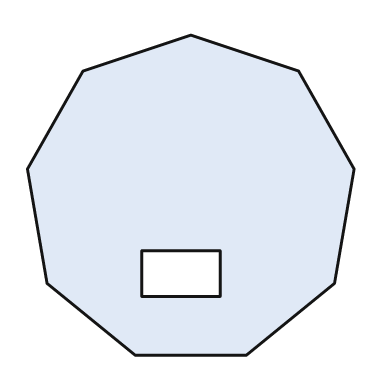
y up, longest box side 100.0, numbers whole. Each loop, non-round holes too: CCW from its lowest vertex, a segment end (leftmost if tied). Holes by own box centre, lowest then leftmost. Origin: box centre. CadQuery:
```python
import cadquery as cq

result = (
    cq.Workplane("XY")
    .moveTo(-17.0, -49.0)
    .lineTo(17.0, -49.0)
    .lineTo(44.0, -27.0)
    .lineTo(50.0, 8.0)
    .lineTo(33.0, 38.0)
    .lineTo(0.0, 49.0)
    .lineTo(-33.0, 38.0)
    .lineTo(-50.0, 8.0)
    .lineTo(-44.0, -27.0)
    .close()
    .moveTo(-15.0, -31.0)
    .lineTo(9.0, -31.0)
    .lineTo(9.0, -17.0)
    .lineTo(-15.0, -17.0)
    .close()
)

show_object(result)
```